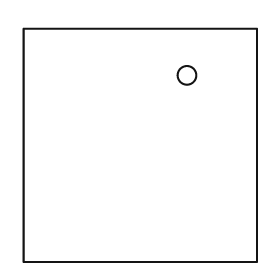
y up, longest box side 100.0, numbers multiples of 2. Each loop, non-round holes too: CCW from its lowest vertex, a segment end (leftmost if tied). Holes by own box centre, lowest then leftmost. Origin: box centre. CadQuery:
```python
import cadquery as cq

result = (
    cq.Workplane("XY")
    .moveTo(-50.0, -50.0)
    .lineTo(50.0, -50.0)
    .lineTo(50.0, 50.0)
    .lineTo(-50.0, 50.0)
    .close()
    .moveTo(20.0, 30.0)
    .circle(4.0)
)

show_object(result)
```